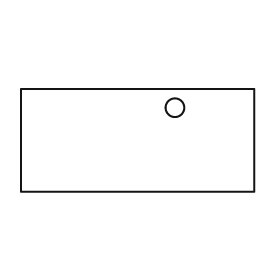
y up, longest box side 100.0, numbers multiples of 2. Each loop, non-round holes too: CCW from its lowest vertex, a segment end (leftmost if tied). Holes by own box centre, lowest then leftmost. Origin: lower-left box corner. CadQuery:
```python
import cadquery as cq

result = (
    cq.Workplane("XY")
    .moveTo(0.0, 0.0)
    .lineTo(100.0, 0.0)
    .lineTo(100.0, 44.0)
    .lineTo(0.0, 44.0)
    .close()
    .moveTo(66.0, 36.0)
    .circle(4.0)
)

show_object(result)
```